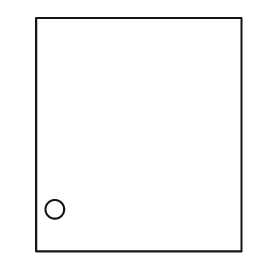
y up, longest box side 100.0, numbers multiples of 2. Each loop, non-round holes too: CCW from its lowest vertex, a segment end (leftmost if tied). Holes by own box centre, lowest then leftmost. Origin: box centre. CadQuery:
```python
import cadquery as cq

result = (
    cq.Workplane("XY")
    .moveTo(-44.0, -50.0)
    .lineTo(44.0, -50.0)
    .lineTo(44.0, 50.0)
    .lineTo(-44.0, 50.0)
    .close()
    .moveTo(-36.0, -32.0)
    .circle(4.0)
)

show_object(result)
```